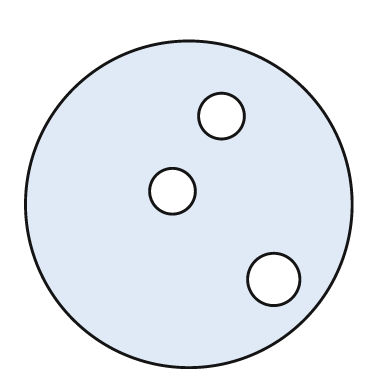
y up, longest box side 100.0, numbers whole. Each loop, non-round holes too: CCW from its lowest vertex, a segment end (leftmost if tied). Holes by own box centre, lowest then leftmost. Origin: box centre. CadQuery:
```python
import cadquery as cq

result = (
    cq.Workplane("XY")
    .moveTo(0.0, 0.0)
    .circle(50.0)
    .moveTo(26.0, -23.0)
    .circle(8.0)
    .moveTo(-5.0, 4.0)
    .circle(7.0)
    .moveTo(10.0, 27.0)
    .circle(7.0)
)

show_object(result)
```